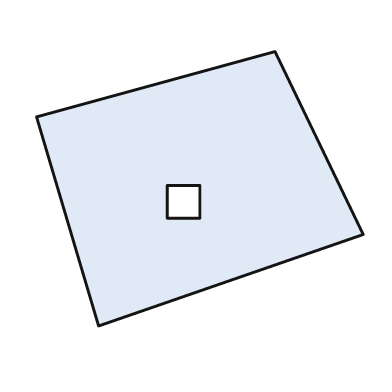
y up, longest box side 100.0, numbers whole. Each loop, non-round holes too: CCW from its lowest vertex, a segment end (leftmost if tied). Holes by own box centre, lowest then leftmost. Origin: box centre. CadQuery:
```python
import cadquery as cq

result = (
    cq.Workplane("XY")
    .moveTo(-31.0, -42.0)
    .lineTo(50.0, -14.0)
    .lineTo(23.0, 42.0)
    .lineTo(-50.0, 22.0)
    .close()
    .moveTo(-10.0, -9.0)
    .lineTo(0.0, -9.0)
    .lineTo(0.0, 1.0)
    .lineTo(-10.0, 1.0)
    .close()
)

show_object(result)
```